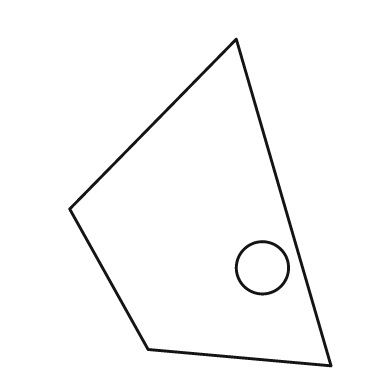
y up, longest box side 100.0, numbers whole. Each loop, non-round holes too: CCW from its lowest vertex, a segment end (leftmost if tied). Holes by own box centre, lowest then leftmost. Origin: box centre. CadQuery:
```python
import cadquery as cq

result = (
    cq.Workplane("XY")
    .moveTo(40.0, -50.0)
    .lineTo(11.0, 50.0)
    .lineTo(-40.0, -2.0)
    .lineTo(-16.0, -45.0)
    .close()
    .moveTo(19.0, -20.0)
    .circle(8.0)
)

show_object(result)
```